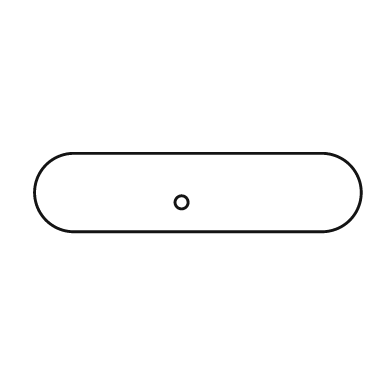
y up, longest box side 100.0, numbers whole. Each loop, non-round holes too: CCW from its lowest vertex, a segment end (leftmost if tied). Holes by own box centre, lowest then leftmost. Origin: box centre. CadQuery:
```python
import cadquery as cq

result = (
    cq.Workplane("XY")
    .moveTo(-38.0, -12.0)
    .lineTo(38.0, -12.0)
    .threePointArc((50.0, 0.0), (38.0, 12.0))
    .lineTo(-38.0, 12.0)
    .threePointArc((-50.0, 0.0), (-38.0, -12.0))
    .close()
    .moveTo(-5.0, -3.0)
    .circle(2.0)
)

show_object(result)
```